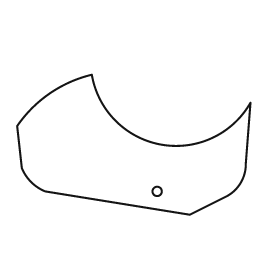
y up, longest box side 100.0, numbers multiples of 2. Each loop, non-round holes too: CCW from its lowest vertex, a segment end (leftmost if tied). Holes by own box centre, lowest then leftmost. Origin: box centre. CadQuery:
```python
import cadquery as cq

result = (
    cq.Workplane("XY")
    .moveTo(24.0, -30.0)
    .lineTo(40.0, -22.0)
    .threePointArc((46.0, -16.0), (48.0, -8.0))
    .lineTo(50.0, 18.0)
    .threePointArc((12.0, 0.0), (-18.0, 30.0))
    .threePointArc((-36.0, 22.0), (-50.0, 8.0))
    .lineTo(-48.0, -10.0)
    .threePointArc((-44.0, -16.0), (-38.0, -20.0))
    .close()
    .moveTo(10.0, -20.0)
    .circle(2.0)
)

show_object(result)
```